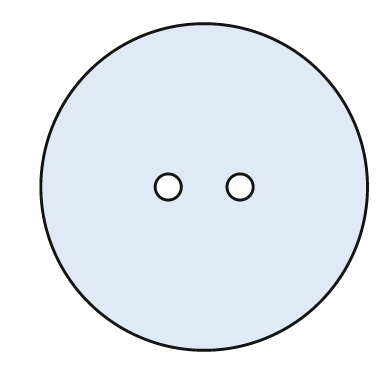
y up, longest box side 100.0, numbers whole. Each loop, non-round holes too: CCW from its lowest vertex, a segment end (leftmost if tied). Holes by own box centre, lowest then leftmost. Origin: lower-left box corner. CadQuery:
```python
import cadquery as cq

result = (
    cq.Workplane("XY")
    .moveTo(50.0, 50.0)
    .circle(50.0)
    .moveTo(39.0, 50.0)
    .circle(4.0)
    .moveTo(61.0, 50.0)
    .circle(4.0)
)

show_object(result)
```